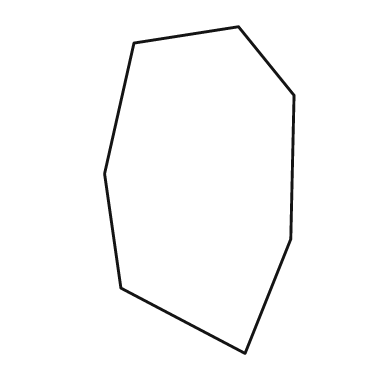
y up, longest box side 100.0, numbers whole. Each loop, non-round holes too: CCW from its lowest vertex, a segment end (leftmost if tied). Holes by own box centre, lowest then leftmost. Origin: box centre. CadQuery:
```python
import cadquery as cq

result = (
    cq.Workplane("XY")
    .moveTo(14.0, -50.0)
    .lineTo(28.0, -15.0)
    .lineTo(29.0, 29.0)
    .lineTo(12.0, 50.0)
    .lineTo(-20.0, 45.0)
    .lineTo(-29.0, 5.0)
    .lineTo(-24.0, -30.0)
    .close()
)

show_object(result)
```